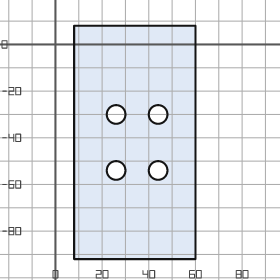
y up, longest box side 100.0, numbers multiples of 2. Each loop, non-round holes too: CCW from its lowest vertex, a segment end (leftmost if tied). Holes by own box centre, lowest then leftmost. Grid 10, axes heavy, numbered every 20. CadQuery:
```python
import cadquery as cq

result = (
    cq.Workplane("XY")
    .moveTo(8.0, -92.0)
    .lineTo(60.0, -92.0)
    .lineTo(60.0, 8.0)
    .lineTo(8.0, 8.0)
    .close()
    .moveTo(26.0, -54.0)
    .circle(4.0)
    .moveTo(44.0, -54.0)
    .circle(4.0)
    .moveTo(26.0, -30.0)
    .circle(4.0)
    .moveTo(44.0, -30.0)
    .circle(4.0)
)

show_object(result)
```